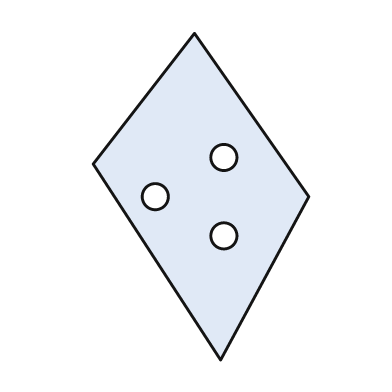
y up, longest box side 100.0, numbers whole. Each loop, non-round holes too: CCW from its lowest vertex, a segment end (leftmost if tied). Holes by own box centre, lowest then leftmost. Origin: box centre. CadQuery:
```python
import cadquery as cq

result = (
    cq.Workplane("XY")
    .moveTo(6.0, -50.0)
    .lineTo(33.0, 0.0)
    .lineTo(-2.0, 50.0)
    .lineTo(-33.0, 10.0)
    .close()
    .moveTo(7.0, -12.0)
    .circle(4.0)
    .moveTo(-14.0, 0.0)
    .circle(4.0)
    .moveTo(7.0, 12.0)
    .circle(4.0)
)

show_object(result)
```